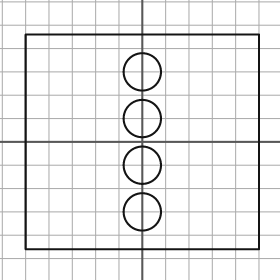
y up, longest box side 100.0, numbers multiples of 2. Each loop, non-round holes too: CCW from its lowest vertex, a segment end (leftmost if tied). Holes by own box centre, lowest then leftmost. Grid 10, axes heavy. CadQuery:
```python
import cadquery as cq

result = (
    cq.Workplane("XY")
    .moveTo(-50.0, -46.0)
    .lineTo(50.0, -46.0)
    .lineTo(50.0, 46.0)
    .lineTo(-50.0, 46.0)
    .close()
    .moveTo(0.0, -30.0)
    .circle(8.0)
    .moveTo(0.0, -10.0)
    .circle(8.0)
    .moveTo(0.0, 10.0)
    .circle(8.0)
    .moveTo(0.0, 30.0)
    .circle(8.0)
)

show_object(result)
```